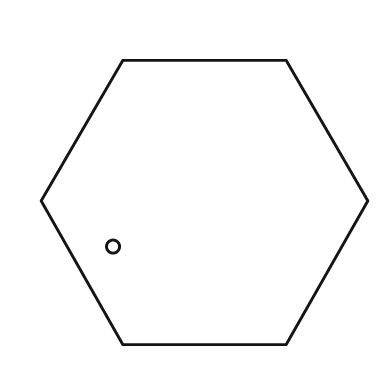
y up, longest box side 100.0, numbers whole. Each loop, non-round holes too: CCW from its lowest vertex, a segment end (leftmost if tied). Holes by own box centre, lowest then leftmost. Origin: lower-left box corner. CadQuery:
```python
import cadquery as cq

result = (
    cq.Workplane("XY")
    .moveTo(25.0, 0.0)
    .lineTo(75.0, 0.0)
    .lineTo(100.0, 44.0)
    .lineTo(75.0, 87.0)
    .lineTo(25.0, 87.0)
    .lineTo(0.0, 44.0)
    .close()
    .moveTo(22.0, 30.0)
    .circle(2.0)
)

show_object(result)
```